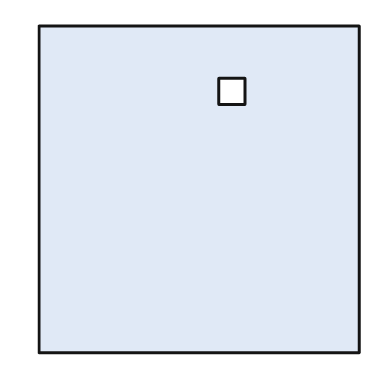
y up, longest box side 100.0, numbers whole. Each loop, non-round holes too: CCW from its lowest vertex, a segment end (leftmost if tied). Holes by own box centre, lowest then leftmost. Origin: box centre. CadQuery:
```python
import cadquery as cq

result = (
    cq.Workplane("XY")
    .moveTo(-49.0, -50.0)
    .lineTo(49.0, -50.0)
    .lineTo(49.0, 50.0)
    .lineTo(-49.0, 50.0)
    .close()
    .moveTo(6.0, 26.0)
    .lineTo(14.0, 26.0)
    .lineTo(14.0, 34.0)
    .lineTo(6.0, 34.0)
    .close()
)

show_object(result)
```